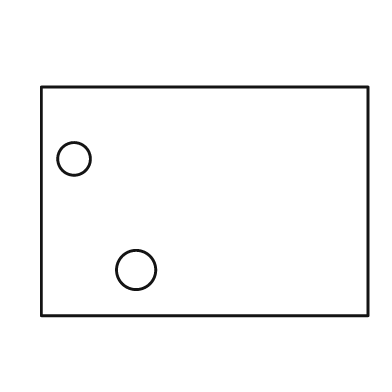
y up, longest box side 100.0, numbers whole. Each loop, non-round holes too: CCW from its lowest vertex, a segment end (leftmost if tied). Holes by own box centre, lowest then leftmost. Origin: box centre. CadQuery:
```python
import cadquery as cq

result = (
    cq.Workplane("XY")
    .moveTo(-50.0, -35.0)
    .lineTo(50.0, -35.0)
    .lineTo(50.0, 35.0)
    .lineTo(-50.0, 35.0)
    .close()
    .moveTo(-21.0, -21.0)
    .circle(6.0)
    .moveTo(-40.0, 13.0)
    .circle(5.0)
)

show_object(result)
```